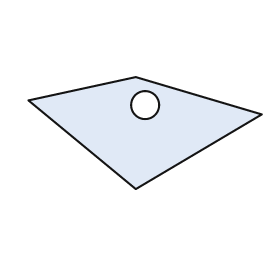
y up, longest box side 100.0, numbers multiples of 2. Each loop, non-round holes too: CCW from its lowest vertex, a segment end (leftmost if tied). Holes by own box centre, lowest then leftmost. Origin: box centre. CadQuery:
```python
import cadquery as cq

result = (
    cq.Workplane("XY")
    .moveTo(-4.0, -24.0)
    .lineTo(50.0, 8.0)
    .lineTo(-4.0, 24.0)
    .lineTo(-50.0, 14.0)
    .close()
    .moveTo(0.0, 12.0)
    .circle(6.0)
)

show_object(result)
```